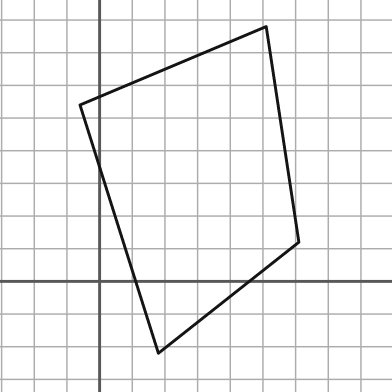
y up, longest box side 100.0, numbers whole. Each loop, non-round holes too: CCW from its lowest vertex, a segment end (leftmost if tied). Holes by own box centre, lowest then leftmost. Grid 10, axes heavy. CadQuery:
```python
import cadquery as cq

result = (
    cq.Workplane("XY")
    .moveTo(18.0, -22.0)
    .lineTo(61.0, 12.0)
    .lineTo(51.0, 78.0)
    .lineTo(-6.0, 54.0)
    .close()
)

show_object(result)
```